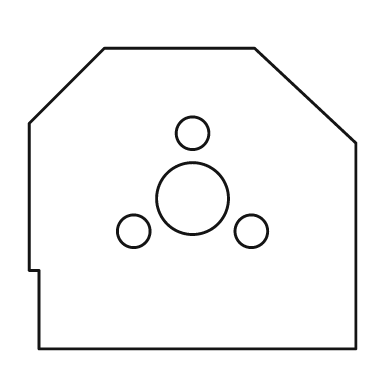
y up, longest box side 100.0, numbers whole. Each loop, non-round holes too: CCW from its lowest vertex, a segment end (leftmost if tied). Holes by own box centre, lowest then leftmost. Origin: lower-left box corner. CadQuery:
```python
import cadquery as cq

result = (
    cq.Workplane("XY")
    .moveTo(3.0, 0.0)
    .lineTo(100.0, 0.0)
    .lineTo(100.0, 63.0)
    .lineTo(69.0, 92.0)
    .lineTo(23.0, 92.0)
    .lineTo(0.0, 69.0)
    .lineTo(0.0, 24.0)
    .lineTo(3.0, 24.0)
    .close()
    .moveTo(32.0, 36.0)
    .circle(5.0)
    .moveTo(68.0, 36.0)
    .circle(5.0)
    .moveTo(50.0, 46.0)
    .circle(11.0)
    .moveTo(50.0, 66.0)
    .circle(5.0)
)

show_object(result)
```